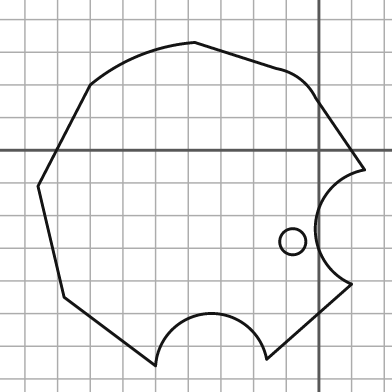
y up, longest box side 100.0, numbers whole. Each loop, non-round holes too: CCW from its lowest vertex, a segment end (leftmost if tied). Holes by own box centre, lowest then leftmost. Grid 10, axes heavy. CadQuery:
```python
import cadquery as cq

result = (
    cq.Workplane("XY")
    .moveTo(-50.0, -66.0)
    .threePointArc((-34.0, -50.0), (-16.0, -64.0))
    .lineTo(10.0, -41.0)
    .threePointArc((-1.0, -22.0), (14.0, -6.0))
    .lineTo(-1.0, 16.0)
    .threePointArc((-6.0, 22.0), (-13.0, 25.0))
    .lineTo(-38.0, 33.0)
    .threePointArc((-55.0, 29.0), (-70.0, 20.0))
    .lineTo(-86.0, -11.0)
    .lineTo(-78.0, -45.0)
    .close()
    .moveTo(-8.0, -28.0)
    .circle(4.0)
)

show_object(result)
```